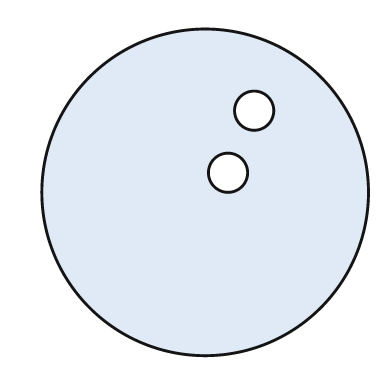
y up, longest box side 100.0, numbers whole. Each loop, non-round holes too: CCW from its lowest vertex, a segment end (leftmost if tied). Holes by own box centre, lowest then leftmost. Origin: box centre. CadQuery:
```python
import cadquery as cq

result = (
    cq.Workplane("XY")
    .moveTo(0.0, 0.0)
    .circle(50.0)
    .moveTo(7.0, 6.0)
    .circle(6.0)
    .moveTo(15.0, 25.0)
    .circle(6.0)
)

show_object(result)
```